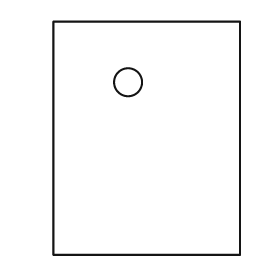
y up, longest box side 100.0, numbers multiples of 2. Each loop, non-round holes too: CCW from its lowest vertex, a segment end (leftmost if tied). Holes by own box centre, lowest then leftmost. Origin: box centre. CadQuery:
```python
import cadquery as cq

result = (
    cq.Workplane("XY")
    .moveTo(-40.0, -50.0)
    .lineTo(40.0, -50.0)
    .lineTo(40.0, 50.0)
    .lineTo(-40.0, 50.0)
    .close()
    .moveTo(-8.0, 24.0)
    .circle(6.0)
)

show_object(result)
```